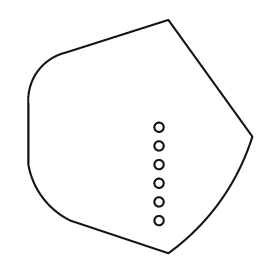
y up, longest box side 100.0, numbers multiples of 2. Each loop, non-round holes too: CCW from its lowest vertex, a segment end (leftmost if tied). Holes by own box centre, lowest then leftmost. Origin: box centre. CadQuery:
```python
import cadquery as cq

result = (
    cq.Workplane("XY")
    .moveTo(12.0, -50.0)
    .threePointArc((34.0, -28.0), (48.0, 0.0))
    .lineTo(12.0, 50.0)
    .lineTo(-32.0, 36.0)
    .threePointArc((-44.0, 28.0), (-48.0, 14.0))
    .lineTo(-48.0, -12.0)
    .threePointArc((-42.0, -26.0), (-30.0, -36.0))
    .close()
    .moveTo(8.0, -36.0)
    .circle(2.0)
    .moveTo(8.0, -28.0)
    .circle(2.0)
    .moveTo(8.0, -20.0)
    .circle(2.0)
    .moveTo(8.0, -12.0)
    .circle(2.0)
    .moveTo(8.0, -4.0)
    .circle(2.0)
    .moveTo(8.0, 4.0)
    .circle(2.0)
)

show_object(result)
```